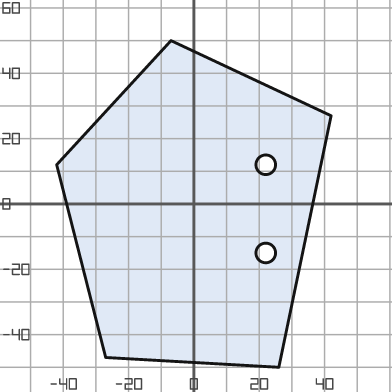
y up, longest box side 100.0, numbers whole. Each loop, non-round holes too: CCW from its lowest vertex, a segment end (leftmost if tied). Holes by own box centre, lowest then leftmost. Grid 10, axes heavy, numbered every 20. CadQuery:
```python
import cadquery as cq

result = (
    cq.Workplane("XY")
    .moveTo(26.0, -50.0)
    .lineTo(42.0, 27.0)
    .lineTo(-7.0, 50.0)
    .lineTo(-42.0, 12.0)
    .lineTo(-27.0, -47.0)
    .close()
    .moveTo(22.0, -15.0)
    .circle(3.0)
    .moveTo(22.0, 12.0)
    .circle(3.0)
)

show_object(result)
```